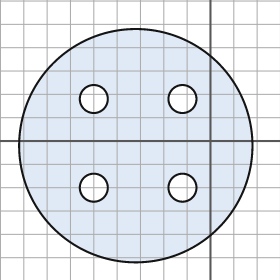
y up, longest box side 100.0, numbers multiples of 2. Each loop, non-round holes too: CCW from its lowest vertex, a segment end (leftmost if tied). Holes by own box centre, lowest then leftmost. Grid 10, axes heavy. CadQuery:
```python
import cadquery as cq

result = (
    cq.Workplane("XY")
    .moveTo(-32.0, -2.0)
    .circle(50.0)
    .moveTo(-50.0, -20.0)
    .circle(6.0)
    .moveTo(-12.0, -20.0)
    .circle(6.0)
    .moveTo(-50.0, 18.0)
    .circle(6.0)
    .moveTo(-12.0, 18.0)
    .circle(6.0)
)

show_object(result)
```